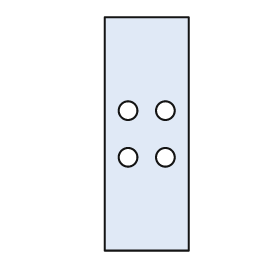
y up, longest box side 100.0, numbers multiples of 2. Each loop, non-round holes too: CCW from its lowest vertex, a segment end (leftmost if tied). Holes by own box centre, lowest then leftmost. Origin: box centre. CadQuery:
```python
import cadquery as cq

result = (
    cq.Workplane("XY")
    .moveTo(-18.0, -50.0)
    .lineTo(18.0, -50.0)
    .lineTo(18.0, 50.0)
    .lineTo(-18.0, 50.0)
    .close()
    .moveTo(-8.0, -10.0)
    .circle(4.0)
    .moveTo(8.0, -10.0)
    .circle(4.0)
    .moveTo(-8.0, 10.0)
    .circle(4.0)
    .moveTo(8.0, 10.0)
    .circle(4.0)
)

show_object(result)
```